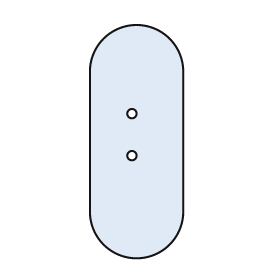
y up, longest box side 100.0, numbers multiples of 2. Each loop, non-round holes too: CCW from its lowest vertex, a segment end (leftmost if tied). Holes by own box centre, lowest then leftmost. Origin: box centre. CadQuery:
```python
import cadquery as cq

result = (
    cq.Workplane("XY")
    .moveTo(-20.0, -30.0)
    .threePointArc((0.0, -50.0), (20.0, -30.0))
    .lineTo(20.0, 30.0)
    .threePointArc((0.0, 50.0), (-20.0, 30.0))
    .close()
    .moveTo(-2.0, -6.0)
    .circle(2.0)
    .moveTo(-2.0, 12.0)
    .circle(2.0)
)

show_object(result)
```